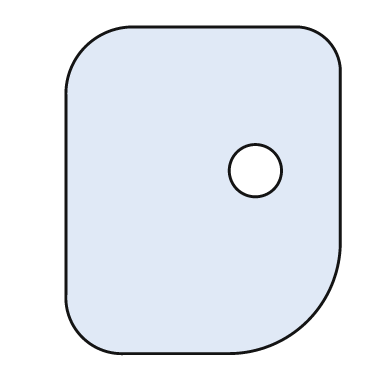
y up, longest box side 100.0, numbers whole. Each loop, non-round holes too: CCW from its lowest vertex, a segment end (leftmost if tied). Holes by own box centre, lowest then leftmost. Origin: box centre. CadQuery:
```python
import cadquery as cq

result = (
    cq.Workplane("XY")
    .moveTo(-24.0, -50.0)
    .lineTo(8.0, -50.0)
    .threePointArc((32.0, -40.0), (42.0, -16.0))
    .lineTo(42.0, 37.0)
    .threePointArc((38.0, 46.0), (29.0, 50.0))
    .lineTo(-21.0, 50.0)
    .threePointArc((-36.0, 44.0), (-42.0, 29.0))
    .lineTo(-42.0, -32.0)
    .threePointArc((-37.0, -45.0), (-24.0, -50.0))
    .close()
    .moveTo(16.0, 6.0)
    .circle(8.0)
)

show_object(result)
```